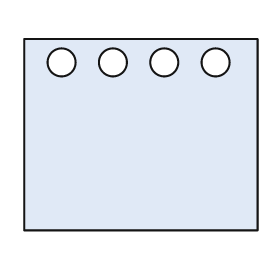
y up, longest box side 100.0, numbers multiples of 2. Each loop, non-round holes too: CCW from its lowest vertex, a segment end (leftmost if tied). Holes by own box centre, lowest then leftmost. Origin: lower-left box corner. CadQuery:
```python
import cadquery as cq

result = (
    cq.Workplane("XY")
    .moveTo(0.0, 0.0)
    .lineTo(100.0, 0.0)
    .lineTo(100.0, 82.0)
    .lineTo(0.0, 82.0)
    .close()
    .moveTo(16.0, 72.0)
    .circle(6.0)
    .moveTo(38.0, 72.0)
    .circle(6.0)
    .moveTo(60.0, 72.0)
    .circle(6.0)
    .moveTo(82.0, 72.0)
    .circle(6.0)
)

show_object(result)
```